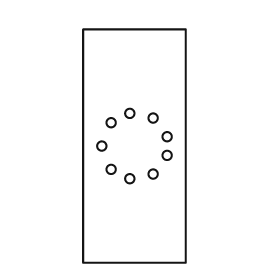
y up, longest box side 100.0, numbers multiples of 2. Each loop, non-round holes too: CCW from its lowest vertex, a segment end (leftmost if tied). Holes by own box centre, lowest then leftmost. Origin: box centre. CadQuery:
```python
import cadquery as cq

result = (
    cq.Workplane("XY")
    .moveTo(-22.0, -50.0)
    .lineTo(22.0, -50.0)
    .lineTo(22.0, 50.0)
    .lineTo(-22.0, 50.0)
    .close()
    .moveTo(-2.0, -14.0)
    .circle(2.0)
    .moveTo(8.0, -12.0)
    .circle(2.0)
    .moveTo(-10.0, -10.0)
    .circle(2.0)
    .moveTo(14.0, -4.0)
    .circle(2.0)
    .moveTo(-14.0, 0.0)
    .circle(2.0)
    .moveTo(14.0, 4.0)
    .circle(2.0)
    .moveTo(-10.0, 10.0)
    .circle(2.0)
    .moveTo(8.0, 12.0)
    .circle(2.0)
    .moveTo(-2.0, 14.0)
    .circle(2.0)
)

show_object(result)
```